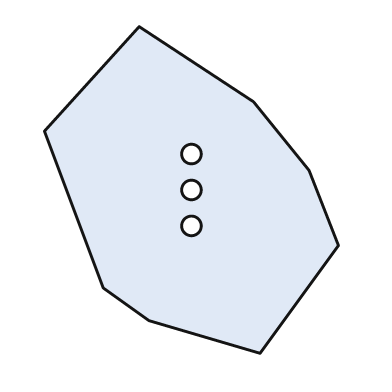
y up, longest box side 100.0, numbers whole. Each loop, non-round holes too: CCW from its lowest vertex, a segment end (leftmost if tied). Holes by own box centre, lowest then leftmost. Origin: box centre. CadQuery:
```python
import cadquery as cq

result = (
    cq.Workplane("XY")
    .moveTo(21.0, -50.0)
    .lineTo(45.0, -17.0)
    .lineTo(36.0, 6.0)
    .lineTo(19.0, 27.0)
    .lineTo(-16.0, 50.0)
    .lineTo(-45.0, 18.0)
    .lineTo(-27.0, -30.0)
    .lineTo(-13.0, -40.0)
    .close()
    .moveTo(0.0, -11.0)
    .circle(3.0)
    .moveTo(0.0, 0.0)
    .circle(3.0)
    .moveTo(0.0, 11.0)
    .circle(3.0)
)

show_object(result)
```